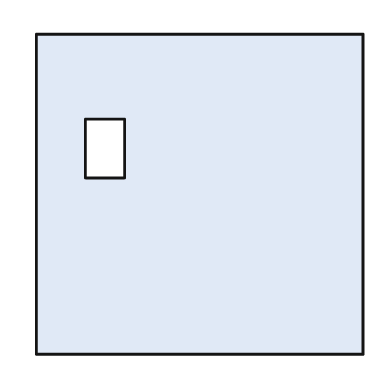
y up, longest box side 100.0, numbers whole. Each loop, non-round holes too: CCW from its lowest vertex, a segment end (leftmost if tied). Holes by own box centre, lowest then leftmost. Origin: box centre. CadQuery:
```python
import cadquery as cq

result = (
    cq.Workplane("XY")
    .moveTo(-50.0, -49.0)
    .lineTo(50.0, -49.0)
    .lineTo(50.0, 49.0)
    .lineTo(-50.0, 49.0)
    .close()
    .moveTo(-35.0, 5.0)
    .lineTo(-23.0, 5.0)
    .lineTo(-23.0, 23.0)
    .lineTo(-35.0, 23.0)
    .close()
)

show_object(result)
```